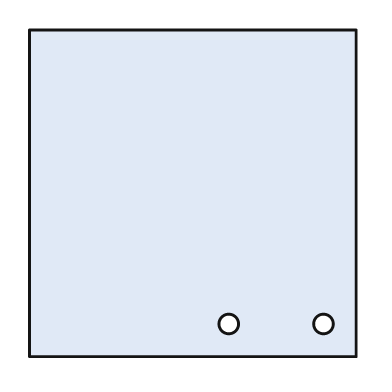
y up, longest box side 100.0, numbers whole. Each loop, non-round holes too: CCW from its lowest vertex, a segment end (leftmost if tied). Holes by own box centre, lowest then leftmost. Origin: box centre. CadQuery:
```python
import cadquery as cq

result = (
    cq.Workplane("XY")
    .moveTo(-50.0, -50.0)
    .lineTo(50.0, -50.0)
    .lineTo(50.0, 50.0)
    .lineTo(-50.0, 50.0)
    .close()
    .moveTo(11.0, -40.0)
    .circle(3.0)
    .moveTo(40.0, -40.0)
    .circle(3.0)
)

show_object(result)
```